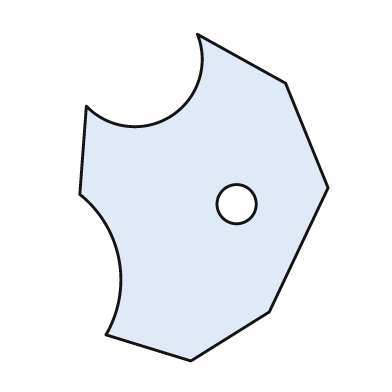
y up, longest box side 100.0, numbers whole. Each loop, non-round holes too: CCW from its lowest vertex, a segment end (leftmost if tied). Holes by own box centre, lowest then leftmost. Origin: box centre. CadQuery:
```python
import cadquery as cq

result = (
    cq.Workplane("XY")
    .moveTo(-4.0, -50.0)
    .lineTo(20.0, -35.0)
    .lineTo(38.0, 3.0)
    .lineTo(25.0, 35.0)
    .lineTo(-2.0, 50.0)
    .threePointArc((-10.0, 25.0), (-36.0, 28.0))
    .lineTo(-38.0, 1.0)
    .threePointArc((-26.0, -19.0), (-30.0, -42.0))
    .close()
    .moveTo(10.0, -2.0)
    .circle(6.0)
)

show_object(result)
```